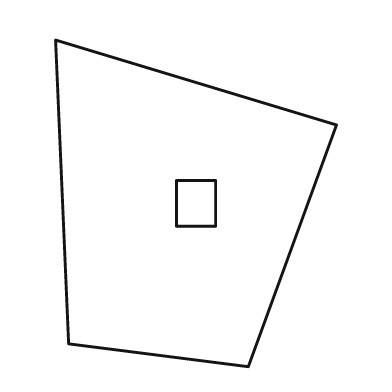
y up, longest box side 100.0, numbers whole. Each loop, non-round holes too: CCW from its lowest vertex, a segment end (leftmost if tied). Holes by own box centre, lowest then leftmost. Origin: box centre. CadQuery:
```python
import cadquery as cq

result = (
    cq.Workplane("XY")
    .moveTo(16.0, -50.0)
    .lineTo(43.0, 24.0)
    .lineTo(-43.0, 50.0)
    .lineTo(-39.0, -43.0)
    .close()
    .moveTo(-6.0, -7.0)
    .lineTo(6.0, -7.0)
    .lineTo(6.0, 7.0)
    .lineTo(-6.0, 7.0)
    .close()
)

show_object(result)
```